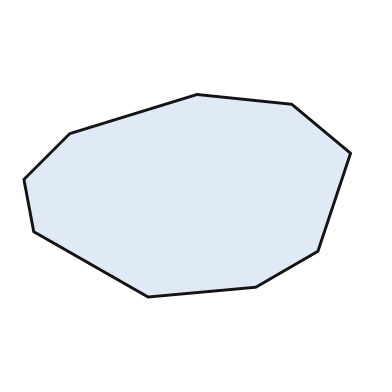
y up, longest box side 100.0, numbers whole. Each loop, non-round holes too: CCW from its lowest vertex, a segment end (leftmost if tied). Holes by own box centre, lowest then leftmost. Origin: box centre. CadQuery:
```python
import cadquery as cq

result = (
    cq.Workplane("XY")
    .moveTo(-12.0, -31.0)
    .lineTo(21.0, -28.0)
    .lineTo(40.0, -17.0)
    .lineTo(50.0, 13.0)
    .lineTo(32.0, 28.0)
    .lineTo(3.0, 31.0)
    .lineTo(-36.0, 19.0)
    .lineTo(-50.0, 5.0)
    .lineTo(-47.0, -11.0)
    .close()
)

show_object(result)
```